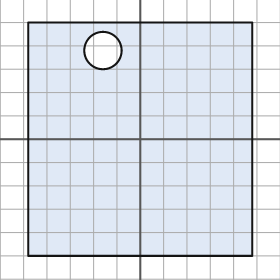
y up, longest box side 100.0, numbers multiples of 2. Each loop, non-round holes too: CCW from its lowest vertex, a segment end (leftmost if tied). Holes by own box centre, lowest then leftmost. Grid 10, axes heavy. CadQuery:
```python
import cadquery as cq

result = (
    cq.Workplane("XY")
    .moveTo(-48.0, -50.0)
    .lineTo(48.0, -50.0)
    .lineTo(48.0, 50.0)
    .lineTo(-48.0, 50.0)
    .close()
    .moveTo(-16.0, 38.0)
    .circle(8.0)
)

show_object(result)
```